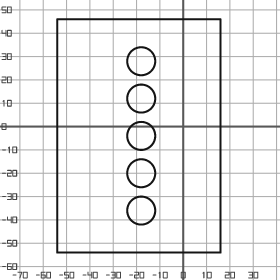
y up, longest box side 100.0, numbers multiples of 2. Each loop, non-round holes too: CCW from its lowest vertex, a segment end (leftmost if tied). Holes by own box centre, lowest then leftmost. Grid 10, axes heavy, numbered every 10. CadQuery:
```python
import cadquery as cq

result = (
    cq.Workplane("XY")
    .moveTo(-54.0, -54.0)
    .lineTo(16.0, -54.0)
    .lineTo(16.0, 46.0)
    .lineTo(-54.0, 46.0)
    .close()
    .moveTo(-18.0, -36.0)
    .circle(6.0)
    .moveTo(-18.0, -20.0)
    .circle(6.0)
    .moveTo(-18.0, -4.0)
    .circle(6.0)
    .moveTo(-18.0, 12.0)
    .circle(6.0)
    .moveTo(-18.0, 28.0)
    .circle(6.0)
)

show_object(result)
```